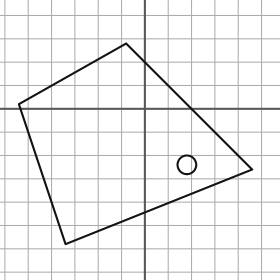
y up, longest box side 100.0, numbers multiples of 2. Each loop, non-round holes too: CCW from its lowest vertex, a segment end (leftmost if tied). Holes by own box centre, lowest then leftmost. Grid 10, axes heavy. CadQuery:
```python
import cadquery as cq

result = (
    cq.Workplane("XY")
    .moveTo(-34.0, -58.0)
    .lineTo(46.0, -26.0)
    .lineTo(-8.0, 28.0)
    .lineTo(-54.0, 2.0)
    .close()
    .moveTo(18.0, -24.0)
    .circle(4.0)
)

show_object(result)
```